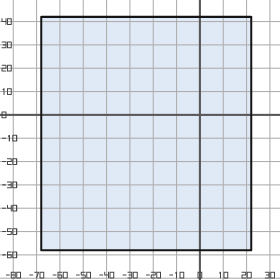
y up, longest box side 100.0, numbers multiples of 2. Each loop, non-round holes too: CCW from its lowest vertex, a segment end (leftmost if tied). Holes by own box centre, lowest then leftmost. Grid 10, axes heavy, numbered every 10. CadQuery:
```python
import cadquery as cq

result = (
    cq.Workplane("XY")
    .moveTo(-68.0, -58.0)
    .lineTo(22.0, -58.0)
    .lineTo(22.0, 42.0)
    .lineTo(-68.0, 42.0)
    .close()
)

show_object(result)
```